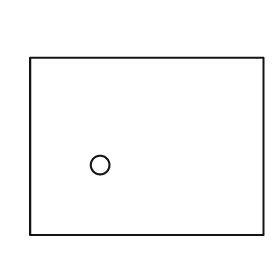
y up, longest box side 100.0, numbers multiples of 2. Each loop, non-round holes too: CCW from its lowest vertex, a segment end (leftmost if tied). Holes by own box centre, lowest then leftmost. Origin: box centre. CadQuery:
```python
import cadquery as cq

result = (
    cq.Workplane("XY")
    .moveTo(-50.0, -38.0)
    .lineTo(50.0, -38.0)
    .lineTo(50.0, 38.0)
    .lineTo(-50.0, 38.0)
    .close()
    .moveTo(-20.0, -8.0)
    .circle(4.0)
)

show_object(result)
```